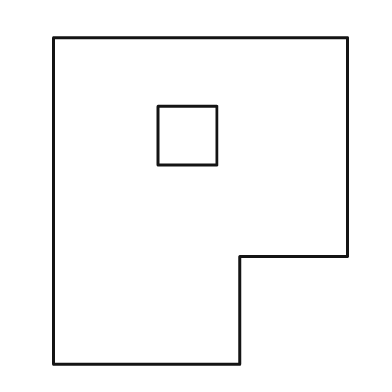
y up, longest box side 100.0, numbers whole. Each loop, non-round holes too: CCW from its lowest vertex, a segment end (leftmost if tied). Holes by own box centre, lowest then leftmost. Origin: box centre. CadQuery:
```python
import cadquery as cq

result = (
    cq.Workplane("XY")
    .moveTo(-45.0, -50.0)
    .lineTo(12.0, -50.0)
    .lineTo(12.0, -17.0)
    .lineTo(45.0, -17.0)
    .lineTo(45.0, 50.0)
    .lineTo(-45.0, 50.0)
    .close()
    .moveTo(-13.0, 11.0)
    .lineTo(5.0, 11.0)
    .lineTo(5.0, 29.0)
    .lineTo(-13.0, 29.0)
    .close()
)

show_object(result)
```